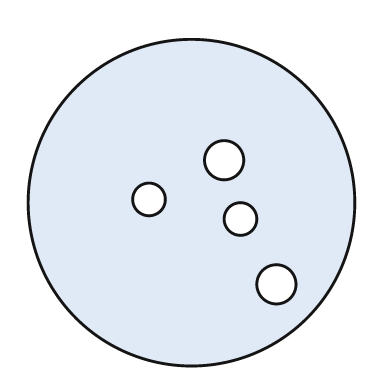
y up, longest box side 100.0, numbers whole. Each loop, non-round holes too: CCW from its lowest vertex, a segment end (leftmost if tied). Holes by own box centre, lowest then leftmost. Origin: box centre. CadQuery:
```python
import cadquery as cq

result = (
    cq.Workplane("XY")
    .moveTo(0.0, 0.0)
    .circle(50.0)
    .moveTo(26.0, -25.0)
    .circle(6.0)
    .moveTo(15.0, -5.0)
    .circle(5.0)
    .moveTo(-13.0, 1.0)
    .circle(5.0)
    .moveTo(10.0, 13.0)
    .circle(6.0)
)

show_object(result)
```